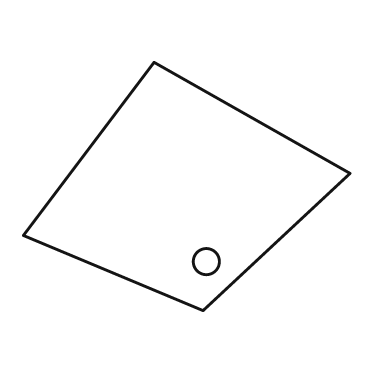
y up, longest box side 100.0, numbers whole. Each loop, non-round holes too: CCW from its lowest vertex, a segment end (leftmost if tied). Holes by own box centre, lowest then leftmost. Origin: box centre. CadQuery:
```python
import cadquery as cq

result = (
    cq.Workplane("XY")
    .moveTo(5.0, -38.0)
    .lineTo(50.0, 4.0)
    .lineTo(-10.0, 38.0)
    .lineTo(-50.0, -15.0)
    .close()
    .moveTo(6.0, -23.0)
    .circle(4.0)
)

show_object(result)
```